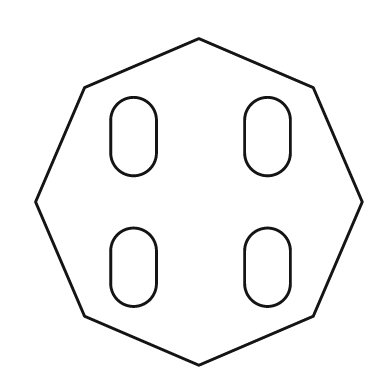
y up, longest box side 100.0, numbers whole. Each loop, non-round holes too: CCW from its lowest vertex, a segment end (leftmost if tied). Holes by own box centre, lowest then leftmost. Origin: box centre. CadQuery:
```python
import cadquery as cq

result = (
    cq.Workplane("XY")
    .moveTo(0.0, -50.0)
    .lineTo(35.0, -35.0)
    .lineTo(50.0, 0.0)
    .lineTo(35.0, 35.0)
    .lineTo(0.0, 50.0)
    .lineTo(-35.0, 35.0)
    .lineTo(-50.0, 0.0)
    .lineTo(-35.0, -35.0)
    .close()
    .moveTo(-27.0, -25.0)
    .threePointArc((-20.0, -32.0), (-13.0, -25.0))
    .lineTo(-13.0, -15.0)
    .threePointArc((-20.0, -8.0), (-27.0, -15.0))
    .close()
    .moveTo(14.0, -25.0)
    .threePointArc((21.0, -32.0), (28.0, -25.0))
    .lineTo(28.0, -15.0)
    .threePointArc((21.0, -8.0), (14.0, -15.0))
    .close()
    .moveTo(-27.0, 15.0)
    .threePointArc((-20.0, 8.0), (-13.0, 15.0))
    .lineTo(-13.0, 25.0)
    .threePointArc((-20.0, 32.0), (-27.0, 25.0))
    .close()
    .moveTo(14.0, 15.0)
    .threePointArc((21.0, 8.0), (28.0, 15.0))
    .lineTo(28.0, 25.0)
    .threePointArc((21.0, 32.0), (14.0, 25.0))
    .close()
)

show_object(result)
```